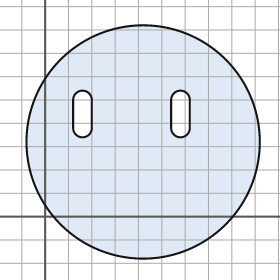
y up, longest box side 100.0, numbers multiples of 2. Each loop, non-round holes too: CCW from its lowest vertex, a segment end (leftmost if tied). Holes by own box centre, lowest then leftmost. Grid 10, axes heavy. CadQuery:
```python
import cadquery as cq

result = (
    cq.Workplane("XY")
    .moveTo(42.0, 32.0)
    .circle(50.0)
    .moveTo(12.0, 38.0)
    .threePointArc((16.0, 34.0), (20.0, 38.0))
    .lineTo(20.0, 50.0)
    .threePointArc((16.0, 54.0), (12.0, 50.0))
    .close()
    .moveTo(54.0, 38.0)
    .threePointArc((58.0, 34.0), (62.0, 38.0))
    .lineTo(62.0, 50.0)
    .threePointArc((58.0, 54.0), (54.0, 50.0))
    .close()
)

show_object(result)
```